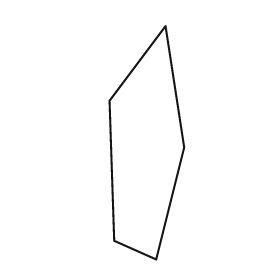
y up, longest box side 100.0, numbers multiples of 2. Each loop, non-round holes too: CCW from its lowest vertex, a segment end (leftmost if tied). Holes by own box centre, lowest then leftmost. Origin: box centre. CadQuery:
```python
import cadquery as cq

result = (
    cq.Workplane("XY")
    .moveTo(4.0, -50.0)
    .lineTo(16.0, -2.0)
    .lineTo(8.0, 50.0)
    .lineTo(-16.0, 18.0)
    .lineTo(-14.0, -42.0)
    .close()
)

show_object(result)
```